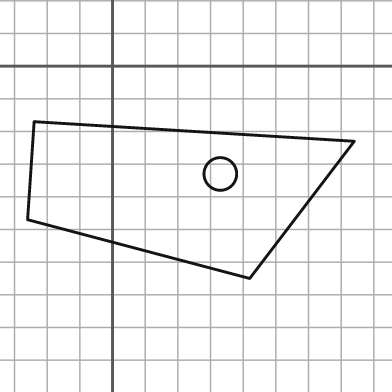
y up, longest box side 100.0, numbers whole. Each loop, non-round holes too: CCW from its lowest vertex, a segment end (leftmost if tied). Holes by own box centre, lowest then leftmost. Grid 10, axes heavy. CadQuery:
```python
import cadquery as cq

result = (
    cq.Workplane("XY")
    .moveTo(42.0, -65.0)
    .lineTo(74.0, -23.0)
    .lineTo(-24.0, -17.0)
    .lineTo(-26.0, -47.0)
    .close()
    .moveTo(33.0, -33.0)
    .circle(5.0)
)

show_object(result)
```